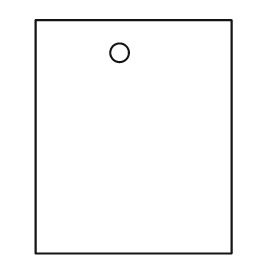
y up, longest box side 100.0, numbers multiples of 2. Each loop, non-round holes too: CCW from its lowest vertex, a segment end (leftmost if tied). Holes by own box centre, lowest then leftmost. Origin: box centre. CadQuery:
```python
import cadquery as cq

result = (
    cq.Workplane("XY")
    .moveTo(-42.0, -50.0)
    .lineTo(42.0, -50.0)
    .lineTo(42.0, 50.0)
    .lineTo(-42.0, 50.0)
    .close()
    .moveTo(-6.0, 36.0)
    .circle(4.0)
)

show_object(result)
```